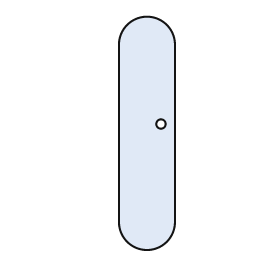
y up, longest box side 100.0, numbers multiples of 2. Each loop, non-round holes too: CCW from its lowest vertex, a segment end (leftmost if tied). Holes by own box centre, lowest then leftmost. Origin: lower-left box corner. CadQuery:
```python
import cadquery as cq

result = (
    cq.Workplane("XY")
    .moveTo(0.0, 12.0)
    .threePointArc((12.0, 0.0), (24.0, 12.0))
    .lineTo(24.0, 88.0)
    .threePointArc((12.0, 100.0), (0.0, 88.0))
    .close()
    .moveTo(18.0, 54.0)
    .circle(2.0)
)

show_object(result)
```